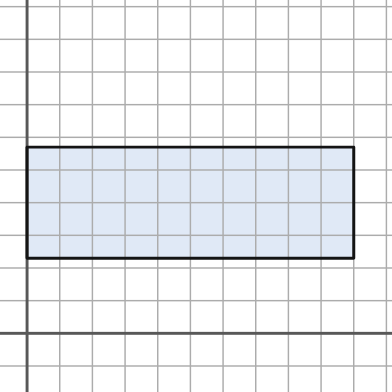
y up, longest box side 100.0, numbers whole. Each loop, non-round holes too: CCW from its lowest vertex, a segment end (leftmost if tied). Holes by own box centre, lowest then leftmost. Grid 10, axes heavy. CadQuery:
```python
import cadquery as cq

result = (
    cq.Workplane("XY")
    .moveTo(0.0, 23.0)
    .lineTo(100.0, 23.0)
    .lineTo(100.0, 57.0)
    .lineTo(0.0, 57.0)
    .close()
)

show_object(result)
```